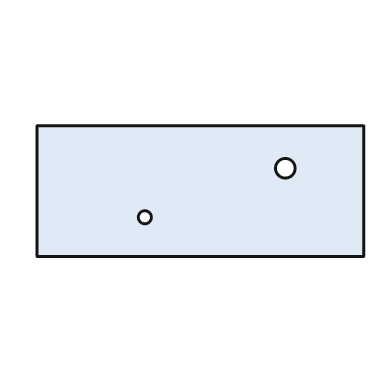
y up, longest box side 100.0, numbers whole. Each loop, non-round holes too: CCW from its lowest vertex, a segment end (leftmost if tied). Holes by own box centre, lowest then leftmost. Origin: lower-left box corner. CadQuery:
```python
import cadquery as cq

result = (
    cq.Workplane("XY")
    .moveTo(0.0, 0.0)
    .lineTo(100.0, 0.0)
    .lineTo(100.0, 40.0)
    .lineTo(0.0, 40.0)
    .close()
    .moveTo(33.0, 12.0)
    .circle(2.0)
    .moveTo(76.0, 27.0)
    .circle(3.0)
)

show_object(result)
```